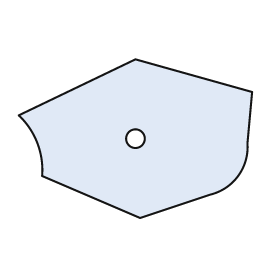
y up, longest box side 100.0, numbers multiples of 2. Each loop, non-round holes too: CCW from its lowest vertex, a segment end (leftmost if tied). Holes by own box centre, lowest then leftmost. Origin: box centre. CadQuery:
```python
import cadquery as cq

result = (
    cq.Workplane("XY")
    .moveTo(2.0, -34.0)
    .lineTo(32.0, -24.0)
    .threePointArc((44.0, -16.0), (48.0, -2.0))
    .lineTo(50.0, 20.0)
    .lineTo(0.0, 34.0)
    .lineTo(-50.0, 10.0)
    .threePointArc((-42.0, -2.0), (-40.0, -16.0))
    .close()
    .moveTo(0.0, 0.0)
    .circle(4.0)
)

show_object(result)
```